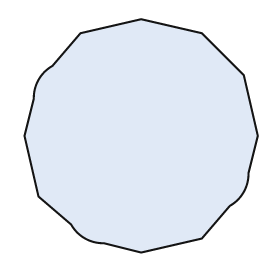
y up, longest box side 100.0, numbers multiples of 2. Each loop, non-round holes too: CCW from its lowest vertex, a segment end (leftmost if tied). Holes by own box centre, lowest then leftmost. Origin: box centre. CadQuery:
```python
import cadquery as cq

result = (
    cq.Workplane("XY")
    .moveTo(0.0, -50.0)
    .lineTo(26.0, -44.0)
    .lineTo(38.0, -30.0)
    .threePointArc((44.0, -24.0), (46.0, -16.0))
    .lineTo(50.0, 0.0)
    .lineTo(44.0, 26.0)
    .lineTo(26.0, 44.0)
    .lineTo(0.0, 50.0)
    .lineTo(-26.0, 44.0)
    .lineTo(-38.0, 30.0)
    .threePointArc((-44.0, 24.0), (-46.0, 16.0))
    .lineTo(-50.0, 0.0)
    .lineTo(-44.0, -26.0)
    .lineTo(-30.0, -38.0)
    .threePointArc((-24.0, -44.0), (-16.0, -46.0))
    .close()
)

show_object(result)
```